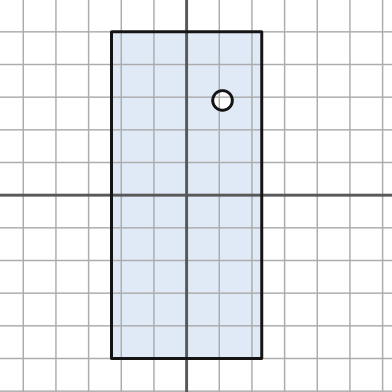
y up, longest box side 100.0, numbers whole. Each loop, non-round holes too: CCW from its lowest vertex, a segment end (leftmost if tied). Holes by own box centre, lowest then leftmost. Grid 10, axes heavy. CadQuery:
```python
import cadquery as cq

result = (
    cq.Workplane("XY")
    .moveTo(-23.0, -50.0)
    .lineTo(23.0, -50.0)
    .lineTo(23.0, 50.0)
    .lineTo(-23.0, 50.0)
    .close()
    .moveTo(11.0, 29.0)
    .circle(3.0)
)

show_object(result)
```